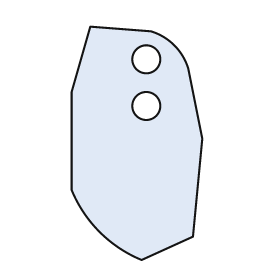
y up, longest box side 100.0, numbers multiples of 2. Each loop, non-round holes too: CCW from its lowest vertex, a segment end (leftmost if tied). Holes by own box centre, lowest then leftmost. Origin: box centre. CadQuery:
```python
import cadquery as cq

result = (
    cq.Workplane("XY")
    .moveTo(2.0, -50.0)
    .lineTo(24.0, -40.0)
    .lineTo(28.0, 2.0)
    .lineTo(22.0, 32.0)
    .threePointArc((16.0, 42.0), (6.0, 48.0))
    .lineTo(-20.0, 50.0)
    .lineTo(-28.0, 22.0)
    .lineTo(-28.0, -20.0)
    .threePointArc((-16.0, -38.0), (2.0, -50.0))
    .close()
    .moveTo(4.0, 16.0)
    .circle(6.0)
    .moveTo(4.0, 36.0)
    .circle(6.0)
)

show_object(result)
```